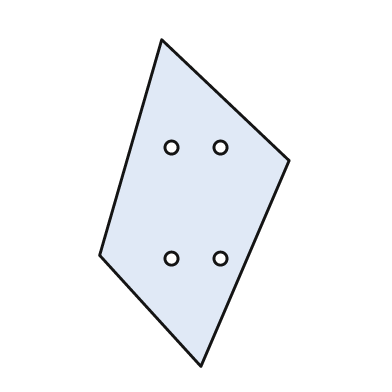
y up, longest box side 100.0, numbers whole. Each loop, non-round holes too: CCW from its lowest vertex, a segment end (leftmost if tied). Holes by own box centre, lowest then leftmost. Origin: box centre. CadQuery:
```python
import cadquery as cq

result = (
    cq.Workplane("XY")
    .moveTo(2.0, -50.0)
    .lineTo(29.0, 13.0)
    .lineTo(-10.0, 50.0)
    .lineTo(-29.0, -16.0)
    .close()
    .moveTo(-7.0, -17.0)
    .circle(2.0)
    .moveTo(8.0, -17.0)
    .circle(2.0)
    .moveTo(-7.0, 17.0)
    .circle(2.0)
    .moveTo(8.0, 17.0)
    .circle(2.0)
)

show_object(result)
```